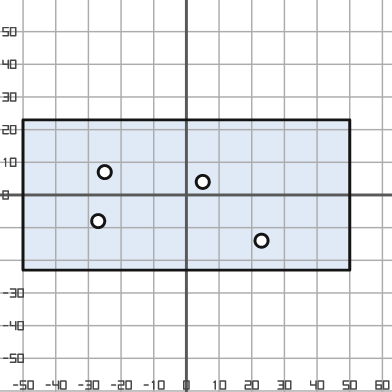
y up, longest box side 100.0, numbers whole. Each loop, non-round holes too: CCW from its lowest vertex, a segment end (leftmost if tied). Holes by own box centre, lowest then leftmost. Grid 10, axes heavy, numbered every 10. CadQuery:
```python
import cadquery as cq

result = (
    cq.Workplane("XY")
    .moveTo(-50.0, -23.0)
    .lineTo(50.0, -23.0)
    .lineTo(50.0, 23.0)
    .lineTo(-50.0, 23.0)
    .close()
    .moveTo(23.0, -14.0)
    .circle(2.0)
    .moveTo(-27.0, -8.0)
    .circle(2.0)
    .moveTo(5.0, 4.0)
    .circle(2.0)
    .moveTo(-25.0, 7.0)
    .circle(2.0)
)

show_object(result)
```